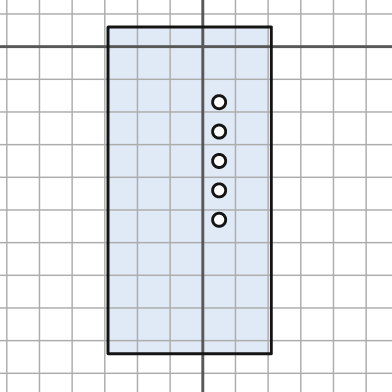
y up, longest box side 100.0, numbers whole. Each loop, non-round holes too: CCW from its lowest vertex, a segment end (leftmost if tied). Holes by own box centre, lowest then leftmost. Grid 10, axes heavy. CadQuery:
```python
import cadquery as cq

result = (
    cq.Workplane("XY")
    .moveTo(-29.0, -94.0)
    .lineTo(21.0, -94.0)
    .lineTo(21.0, 6.0)
    .lineTo(-29.0, 6.0)
    .close()
    .moveTo(5.0, -53.0)
    .circle(2.0)
    .moveTo(5.0, -44.0)
    .circle(2.0)
    .moveTo(5.0, -35.0)
    .circle(2.0)
    .moveTo(5.0, -26.0)
    .circle(2.0)
    .moveTo(5.0, -17.0)
    .circle(2.0)
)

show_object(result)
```